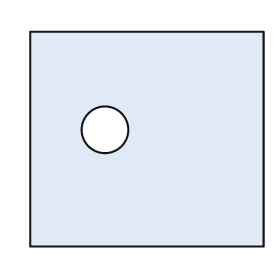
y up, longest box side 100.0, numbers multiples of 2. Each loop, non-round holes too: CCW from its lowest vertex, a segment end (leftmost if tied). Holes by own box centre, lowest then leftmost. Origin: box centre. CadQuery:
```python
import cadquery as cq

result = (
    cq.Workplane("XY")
    .moveTo(-50.0, -46.0)
    .lineTo(50.0, -46.0)
    .lineTo(50.0, 46.0)
    .lineTo(-50.0, 46.0)
    .close()
    .moveTo(-18.0, 4.0)
    .circle(10.0)
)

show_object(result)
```